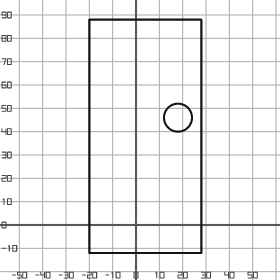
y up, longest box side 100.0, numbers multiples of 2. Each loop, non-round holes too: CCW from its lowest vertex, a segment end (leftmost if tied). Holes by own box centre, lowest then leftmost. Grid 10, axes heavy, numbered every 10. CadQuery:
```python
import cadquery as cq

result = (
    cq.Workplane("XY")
    .moveTo(-20.0, -12.0)
    .lineTo(28.0, -12.0)
    .lineTo(28.0, 88.0)
    .lineTo(-20.0, 88.0)
    .close()
    .moveTo(18.0, 46.0)
    .circle(6.0)
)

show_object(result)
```